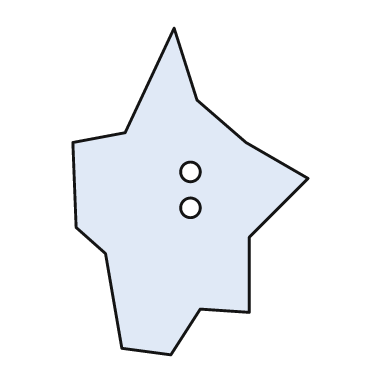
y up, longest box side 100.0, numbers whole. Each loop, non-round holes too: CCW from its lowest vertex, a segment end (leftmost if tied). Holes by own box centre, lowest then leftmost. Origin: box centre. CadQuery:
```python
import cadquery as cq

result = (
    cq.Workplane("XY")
    .moveTo(-6.0, -50.0)
    .lineTo(3.0, -36.0)
    .lineTo(18.0, -37.0)
    .lineTo(18.0, -14.0)
    .lineTo(36.0, 4.0)
    .lineTo(17.0, 15.0)
    .lineTo(2.0, 28.0)
    .lineTo(-5.0, 50.0)
    .lineTo(-20.0, 18.0)
    .lineTo(-36.0, 15.0)
    .lineTo(-35.0, -11.0)
    .lineTo(-26.0, -19.0)
    .lineTo(-21.0, -48.0)
    .close()
    .moveTo(0.0, -5.0)
    .circle(3.0)
    .moveTo(0.0, 6.0)
    .circle(3.0)
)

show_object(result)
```